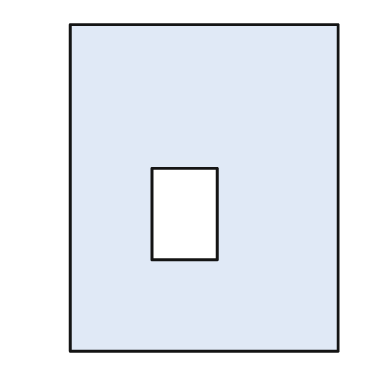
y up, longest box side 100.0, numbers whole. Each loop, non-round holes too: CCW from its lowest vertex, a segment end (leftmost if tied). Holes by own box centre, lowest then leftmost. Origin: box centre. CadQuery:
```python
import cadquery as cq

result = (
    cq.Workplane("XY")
    .moveTo(-41.0, -50.0)
    .lineTo(41.0, -50.0)
    .lineTo(41.0, 50.0)
    .lineTo(-41.0, 50.0)
    .close()
    .moveTo(-16.0, -22.0)
    .lineTo(4.0, -22.0)
    .lineTo(4.0, 6.0)
    .lineTo(-16.0, 6.0)
    .close()
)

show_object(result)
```